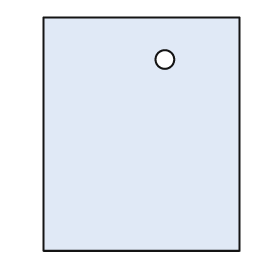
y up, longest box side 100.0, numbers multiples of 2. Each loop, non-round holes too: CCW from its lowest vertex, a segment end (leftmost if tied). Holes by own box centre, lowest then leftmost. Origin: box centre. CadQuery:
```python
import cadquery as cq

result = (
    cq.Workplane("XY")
    .moveTo(-42.0, -50.0)
    .lineTo(42.0, -50.0)
    .lineTo(42.0, 50.0)
    .lineTo(-42.0, 50.0)
    .close()
    .moveTo(10.0, 32.0)
    .circle(4.0)
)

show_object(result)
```